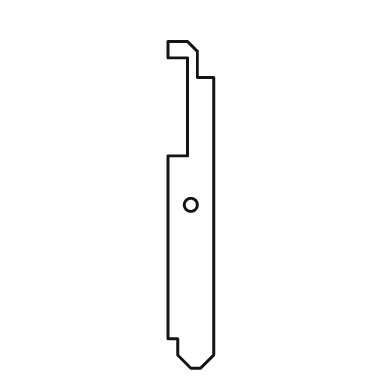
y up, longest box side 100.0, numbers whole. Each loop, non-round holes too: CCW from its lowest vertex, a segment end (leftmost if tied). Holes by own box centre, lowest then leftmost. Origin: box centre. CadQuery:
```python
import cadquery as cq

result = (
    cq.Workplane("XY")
    .moveTo(0.0, -50.0)
    .lineTo(3.0, -50.0)
    .lineTo(7.0, -46.0)
    .lineTo(7.0, 39.0)
    .lineTo(2.0, 39.0)
    .lineTo(2.0, 47.0)
    .lineTo(-1.0, 50.0)
    .lineTo(-7.0, 50.0)
    .lineTo(-7.0, 45.0)
    .lineTo(-1.0, 45.0)
    .lineTo(-1.0, 15.0)
    .lineTo(-7.0, 15.0)
    .lineTo(-7.0, -41.0)
    .lineTo(-4.0, -41.0)
    .lineTo(-4.0, -46.0)
    .close()
    .moveTo(0.0, 0.0)
    .circle(2.0)
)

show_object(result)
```